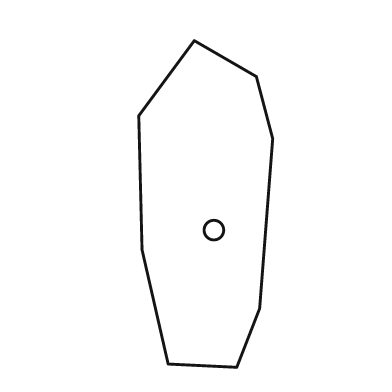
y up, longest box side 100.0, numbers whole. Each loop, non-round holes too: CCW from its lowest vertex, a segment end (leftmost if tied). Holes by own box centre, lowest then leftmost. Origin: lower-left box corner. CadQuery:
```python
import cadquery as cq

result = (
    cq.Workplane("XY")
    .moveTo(30.0, 0.0)
    .lineTo(37.0, 18.0)
    .lineTo(41.0, 70.0)
    .lineTo(36.0, 89.0)
    .lineTo(17.0, 100.0)
    .lineTo(0.0, 77.0)
    .lineTo(1.0, 36.0)
    .lineTo(9.0, 1.0)
    .close()
    .moveTo(23.0, 42.0)
    .circle(3.0)
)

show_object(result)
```